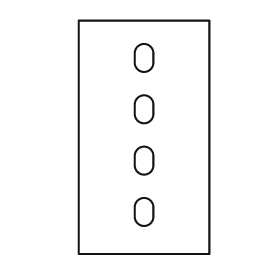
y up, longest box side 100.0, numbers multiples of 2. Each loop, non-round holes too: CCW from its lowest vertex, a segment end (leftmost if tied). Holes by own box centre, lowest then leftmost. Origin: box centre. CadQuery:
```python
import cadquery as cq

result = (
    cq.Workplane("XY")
    .moveTo(-28.0, -50.0)
    .lineTo(28.0, -50.0)
    .lineTo(28.0, 50.0)
    .lineTo(-28.0, 50.0)
    .close()
    .moveTo(-4.0, -34.0)
    .threePointArc((0.0, -38.0), (4.0, -34.0))
    .lineTo(4.0, -30.0)
    .threePointArc((0.0, -26.0), (-4.0, -30.0))
    .close()
    .moveTo(-4.0, -12.0)
    .threePointArc((0.0, -16.0), (4.0, -12.0))
    .lineTo(4.0, -8.0)
    .threePointArc((0.0, -4.0), (-4.0, -8.0))
    .close()
    .moveTo(-4.0, 10.0)
    .threePointArc((0.0, 6.0), (4.0, 10.0))
    .lineTo(4.0, 14.0)
    .threePointArc((0.0, 18.0), (-4.0, 14.0))
    .close()
    .moveTo(-4.0, 32.0)
    .threePointArc((0.0, 28.0), (4.0, 32.0))
    .lineTo(4.0, 36.0)
    .threePointArc((0.0, 40.0), (-4.0, 36.0))
    .close()
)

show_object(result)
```